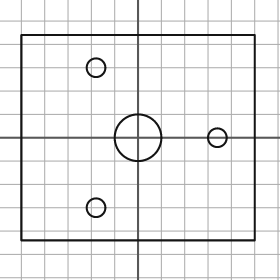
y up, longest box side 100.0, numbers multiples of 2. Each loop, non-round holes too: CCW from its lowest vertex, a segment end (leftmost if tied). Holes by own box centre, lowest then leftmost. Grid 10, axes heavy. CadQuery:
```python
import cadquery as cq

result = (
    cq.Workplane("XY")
    .moveTo(-50.0, -44.0)
    .lineTo(50.0, -44.0)
    .lineTo(50.0, 44.0)
    .lineTo(-50.0, 44.0)
    .close()
    .moveTo(-18.0, -30.0)
    .circle(4.0)
    .moveTo(0.0, 0.0)
    .circle(10.0)
    .moveTo(34.0, 0.0)
    .circle(4.0)
    .moveTo(-18.0, 30.0)
    .circle(4.0)
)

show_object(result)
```